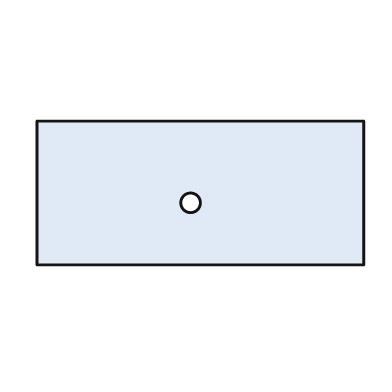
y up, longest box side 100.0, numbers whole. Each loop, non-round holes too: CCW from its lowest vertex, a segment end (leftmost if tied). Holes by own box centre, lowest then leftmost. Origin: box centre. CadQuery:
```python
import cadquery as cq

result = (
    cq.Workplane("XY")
    .moveTo(-50.0, -22.0)
    .lineTo(50.0, -22.0)
    .lineTo(50.0, 22.0)
    .lineTo(-50.0, 22.0)
    .close()
    .moveTo(-3.0, -3.0)
    .circle(3.0)
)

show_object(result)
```